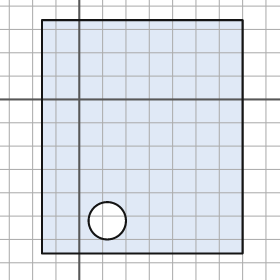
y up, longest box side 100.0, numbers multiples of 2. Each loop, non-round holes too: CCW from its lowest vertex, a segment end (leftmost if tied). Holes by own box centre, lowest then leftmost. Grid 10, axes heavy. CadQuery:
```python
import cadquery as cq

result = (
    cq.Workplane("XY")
    .moveTo(-16.0, -66.0)
    .lineTo(70.0, -66.0)
    .lineTo(70.0, 34.0)
    .lineTo(-16.0, 34.0)
    .close()
    .moveTo(12.0, -52.0)
    .circle(8.0)
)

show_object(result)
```